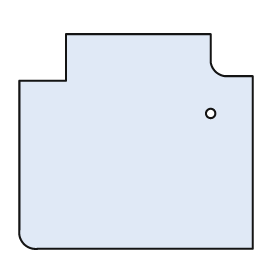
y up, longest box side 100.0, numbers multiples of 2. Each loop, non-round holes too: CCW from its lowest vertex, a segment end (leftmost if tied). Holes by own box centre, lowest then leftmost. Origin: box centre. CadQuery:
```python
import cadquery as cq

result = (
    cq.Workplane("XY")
    .moveTo(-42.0, -46.0)
    .lineTo(50.0, -46.0)
    .lineTo(50.0, 28.0)
    .lineTo(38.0, 28.0)
    .threePointArc((34.0, 30.0), (32.0, 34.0))
    .lineTo(32.0, 46.0)
    .lineTo(-30.0, 46.0)
    .lineTo(-30.0, 26.0)
    .lineTo(-50.0, 26.0)
    .lineTo(-50.0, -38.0)
    .threePointArc((-48.0, -44.0), (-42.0, -46.0))
    .close()
    .moveTo(32.0, 12.0)
    .circle(2.0)
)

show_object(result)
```